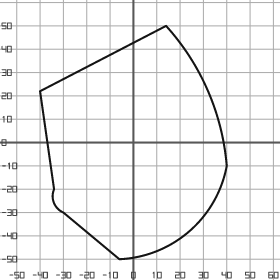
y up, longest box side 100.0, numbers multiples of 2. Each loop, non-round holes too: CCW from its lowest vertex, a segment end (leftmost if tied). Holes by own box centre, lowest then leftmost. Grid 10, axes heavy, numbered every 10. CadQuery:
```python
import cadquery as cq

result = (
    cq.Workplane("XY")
    .moveTo(-6.0, -50.0)
    .threePointArc((24.0, -38.0), (40.0, -10.0))
    .threePointArc((32.0, 22.0), (14.0, 50.0))
    .lineTo(-40.0, 22.0)
    .lineTo(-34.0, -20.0)
    .threePointArc((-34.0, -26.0), (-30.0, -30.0))
    .close()
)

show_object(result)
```